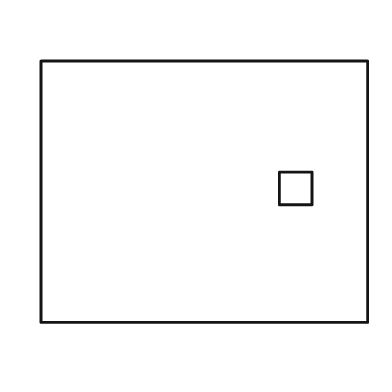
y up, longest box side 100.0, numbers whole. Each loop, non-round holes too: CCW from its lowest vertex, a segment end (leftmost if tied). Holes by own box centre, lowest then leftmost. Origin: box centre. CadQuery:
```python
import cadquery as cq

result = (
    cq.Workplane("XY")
    .moveTo(-50.0, -40.0)
    .lineTo(50.0, -40.0)
    .lineTo(50.0, 40.0)
    .lineTo(-50.0, 40.0)
    .close()
    .moveTo(23.0, -4.0)
    .lineTo(33.0, -4.0)
    .lineTo(33.0, 6.0)
    .lineTo(23.0, 6.0)
    .close()
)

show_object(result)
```